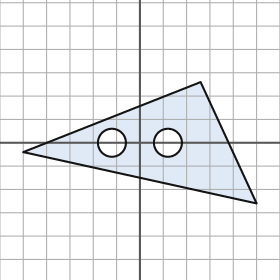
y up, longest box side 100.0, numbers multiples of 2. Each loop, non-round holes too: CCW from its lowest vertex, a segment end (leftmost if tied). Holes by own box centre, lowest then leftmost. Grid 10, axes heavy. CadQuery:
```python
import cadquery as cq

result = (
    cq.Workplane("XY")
    .moveTo(50.0, -26.0)
    .lineTo(26.0, 26.0)
    .lineTo(-50.0, -4.0)
    .close()
    .moveTo(-12.0, 0.0)
    .circle(6.0)
    .moveTo(12.0, 0.0)
    .circle(6.0)
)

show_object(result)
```